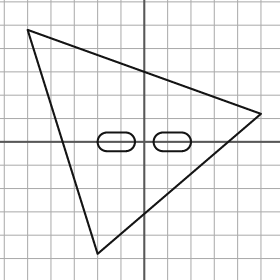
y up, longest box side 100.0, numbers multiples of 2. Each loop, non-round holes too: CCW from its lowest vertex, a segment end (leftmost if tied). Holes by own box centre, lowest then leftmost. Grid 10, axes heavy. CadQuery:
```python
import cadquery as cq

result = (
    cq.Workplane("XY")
    .moveTo(-20.0, -48.0)
    .lineTo(50.0, 12.0)
    .lineTo(-50.0, 48.0)
    .close()
    .moveTo(-16.0, -4.0)
    .lineTo(-8.0, -4.0)
    .threePointArc((-4.0, 0.0), (-8.0, 4.0))
    .lineTo(-16.0, 4.0)
    .threePointArc((-20.0, 0.0), (-16.0, -4.0))
    .close()
    .moveTo(8.0, -4.0)
    .lineTo(16.0, -4.0)
    .threePointArc((20.0, 0.0), (16.0, 4.0))
    .lineTo(8.0, 4.0)
    .threePointArc((4.0, 0.0), (8.0, -4.0))
    .close()
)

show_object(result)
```